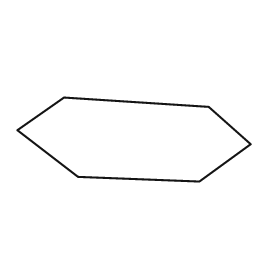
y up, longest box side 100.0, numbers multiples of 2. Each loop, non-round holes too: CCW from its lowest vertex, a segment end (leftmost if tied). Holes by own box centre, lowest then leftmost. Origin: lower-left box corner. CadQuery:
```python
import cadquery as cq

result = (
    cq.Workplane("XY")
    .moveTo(78.0, 0.0)
    .lineTo(100.0, 16.0)
    .lineTo(82.0, 32.0)
    .lineTo(20.0, 36.0)
    .lineTo(0.0, 22.0)
    .lineTo(26.0, 2.0)
    .close()
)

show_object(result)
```